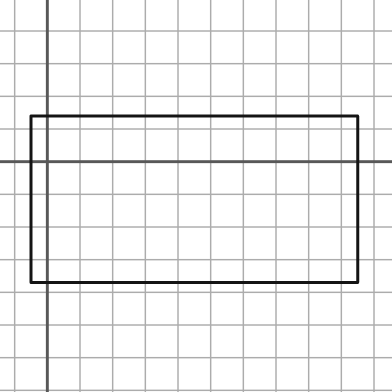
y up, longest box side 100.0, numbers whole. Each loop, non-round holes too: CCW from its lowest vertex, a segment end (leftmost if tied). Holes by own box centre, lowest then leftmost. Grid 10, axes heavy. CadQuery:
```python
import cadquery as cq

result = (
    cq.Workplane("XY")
    .moveTo(-5.0, -37.0)
    .lineTo(95.0, -37.0)
    .lineTo(95.0, 14.0)
    .lineTo(-5.0, 14.0)
    .close()
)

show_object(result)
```